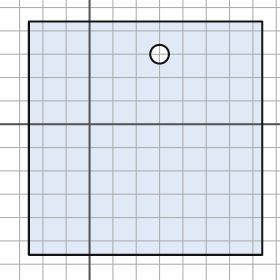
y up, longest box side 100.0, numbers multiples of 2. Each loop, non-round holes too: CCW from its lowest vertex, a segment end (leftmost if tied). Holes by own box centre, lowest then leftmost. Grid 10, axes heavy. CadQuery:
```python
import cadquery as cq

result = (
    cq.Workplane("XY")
    .moveTo(-26.0, -56.0)
    .lineTo(74.0, -56.0)
    .lineTo(74.0, 44.0)
    .lineTo(-26.0, 44.0)
    .close()
    .moveTo(30.0, 30.0)
    .circle(4.0)
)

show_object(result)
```